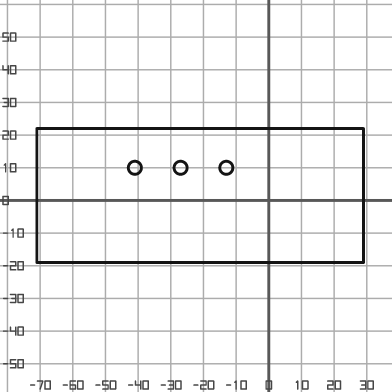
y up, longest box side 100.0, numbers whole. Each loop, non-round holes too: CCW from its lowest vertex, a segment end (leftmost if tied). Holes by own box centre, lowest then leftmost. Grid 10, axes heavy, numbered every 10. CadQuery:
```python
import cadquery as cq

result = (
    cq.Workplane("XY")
    .moveTo(-71.0, -19.0)
    .lineTo(29.0, -19.0)
    .lineTo(29.0, 22.0)
    .lineTo(-71.0, 22.0)
    .close()
    .moveTo(-41.0, 10.0)
    .circle(2.0)
    .moveTo(-27.0, 10.0)
    .circle(2.0)
    .moveTo(-13.0, 10.0)
    .circle(2.0)
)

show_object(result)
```